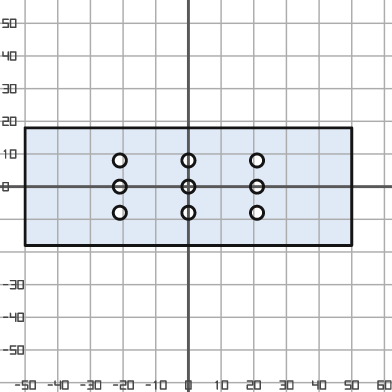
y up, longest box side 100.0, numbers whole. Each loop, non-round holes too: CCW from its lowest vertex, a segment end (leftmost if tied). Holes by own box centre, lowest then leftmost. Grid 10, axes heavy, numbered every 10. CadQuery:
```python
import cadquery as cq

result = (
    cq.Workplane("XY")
    .moveTo(-50.0, -18.0)
    .lineTo(50.0, -18.0)
    .lineTo(50.0, 18.0)
    .lineTo(-50.0, 18.0)
    .close()
    .moveTo(-21.0, -8.0)
    .circle(2.0)
    .moveTo(0.0, -8.0)
    .circle(2.0)
    .moveTo(21.0, -8.0)
    .circle(2.0)
    .moveTo(-21.0, 0.0)
    .circle(2.0)
    .moveTo(0.0, 0.0)
    .circle(2.0)
    .moveTo(21.0, 0.0)
    .circle(2.0)
    .moveTo(-21.0, 8.0)
    .circle(2.0)
    .moveTo(0.0, 8.0)
    .circle(2.0)
    .moveTo(21.0, 8.0)
    .circle(2.0)
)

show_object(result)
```